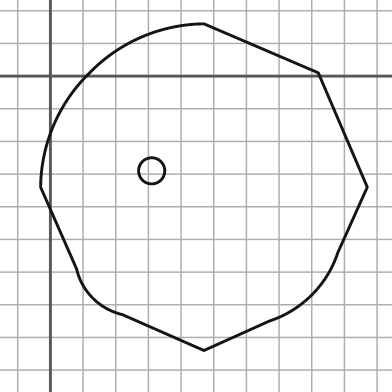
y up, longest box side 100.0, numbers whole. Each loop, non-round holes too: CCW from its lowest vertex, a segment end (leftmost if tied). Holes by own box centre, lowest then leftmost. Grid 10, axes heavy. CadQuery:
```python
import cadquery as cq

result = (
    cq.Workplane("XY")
    .moveTo(47.0, -84.0)
    .lineTo(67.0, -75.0)
    .threePointArc((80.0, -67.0), (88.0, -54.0))
    .lineTo(97.0, -34.0)
    .lineTo(82.0, 1.0)
    .lineTo(47.0, 16.0)
    .threePointArc((28.0, 12.0), (12.0, 1.0))
    .threePointArc((1.0, -15.0), (-3.0, -34.0))
    .lineTo(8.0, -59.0)
    .threePointArc((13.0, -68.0), (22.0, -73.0))
    .close()
    .moveTo(31.0, -29.0)
    .circle(4.0)
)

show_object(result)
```